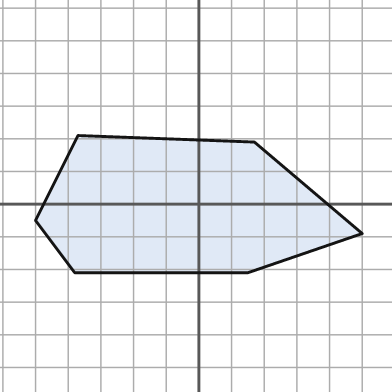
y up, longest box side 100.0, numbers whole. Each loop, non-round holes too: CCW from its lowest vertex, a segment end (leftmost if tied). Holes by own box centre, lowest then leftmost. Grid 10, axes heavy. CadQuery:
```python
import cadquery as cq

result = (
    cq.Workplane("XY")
    .moveTo(-38.0, -21.0)
    .lineTo(15.0, -21.0)
    .lineTo(50.0, -9.0)
    .lineTo(17.0, 19.0)
    .lineTo(-37.0, 21.0)
    .lineTo(-50.0, -5.0)
    .close()
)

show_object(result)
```